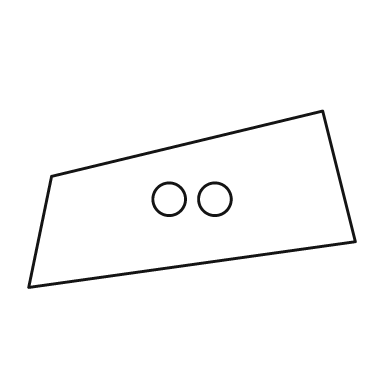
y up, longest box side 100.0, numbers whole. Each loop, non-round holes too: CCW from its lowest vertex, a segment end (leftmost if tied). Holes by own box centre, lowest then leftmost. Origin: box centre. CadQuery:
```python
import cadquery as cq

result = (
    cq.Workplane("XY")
    .moveTo(-50.0, -27.0)
    .lineTo(50.0, -13.0)
    .lineTo(40.0, 27.0)
    .lineTo(-43.0, 7.0)
    .close()
    .moveTo(-7.0, 0.0)
    .circle(5.0)
    .moveTo(7.0, 0.0)
    .circle(5.0)
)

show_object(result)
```